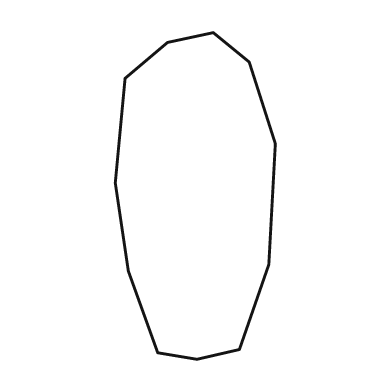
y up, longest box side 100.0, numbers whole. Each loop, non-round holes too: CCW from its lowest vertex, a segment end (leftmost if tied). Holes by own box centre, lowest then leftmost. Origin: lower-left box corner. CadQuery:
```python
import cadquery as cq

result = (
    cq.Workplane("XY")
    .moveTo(25.0, 0.0)
    .lineTo(38.0, 3.0)
    .lineTo(47.0, 29.0)
    .lineTo(49.0, 66.0)
    .lineTo(41.0, 91.0)
    .lineTo(30.0, 100.0)
    .lineTo(16.0, 97.0)
    .lineTo(3.0, 86.0)
    .lineTo(0.0, 54.0)
    .lineTo(4.0, 27.0)
    .lineTo(13.0, 2.0)
    .close()
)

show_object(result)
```